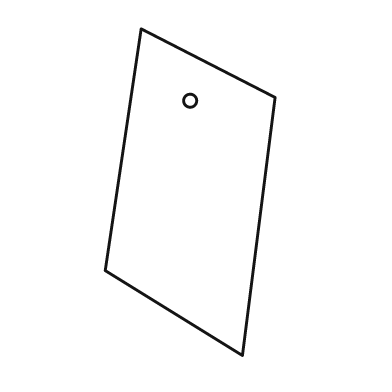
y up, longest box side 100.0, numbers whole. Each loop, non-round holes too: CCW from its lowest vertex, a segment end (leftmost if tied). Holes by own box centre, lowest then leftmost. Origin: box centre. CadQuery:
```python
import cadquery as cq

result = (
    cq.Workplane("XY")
    .moveTo(16.0, -50.0)
    .lineTo(26.0, 29.0)
    .lineTo(-15.0, 50.0)
    .lineTo(-26.0, -24.0)
    .close()
    .moveTo(0.0, 28.0)
    .circle(2.0)
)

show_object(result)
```